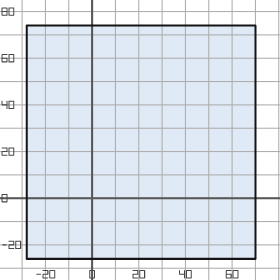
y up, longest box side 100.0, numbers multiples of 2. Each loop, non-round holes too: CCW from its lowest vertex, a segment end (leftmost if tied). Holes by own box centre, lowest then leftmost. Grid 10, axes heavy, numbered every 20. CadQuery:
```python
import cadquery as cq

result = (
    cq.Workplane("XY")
    .moveTo(-28.0, -26.0)
    .lineTo(70.0, -26.0)
    .lineTo(70.0, 74.0)
    .lineTo(-28.0, 74.0)
    .close()
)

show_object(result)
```